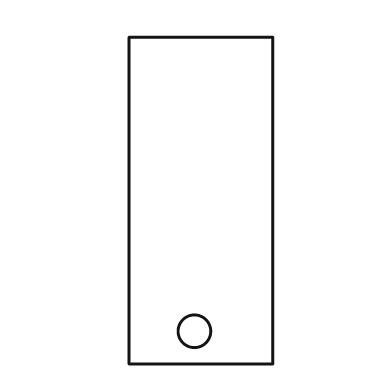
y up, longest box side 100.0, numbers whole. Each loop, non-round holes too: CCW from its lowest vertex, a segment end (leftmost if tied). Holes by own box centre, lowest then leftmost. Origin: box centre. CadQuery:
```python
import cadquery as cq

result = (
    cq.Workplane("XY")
    .moveTo(-22.0, -50.0)
    .lineTo(22.0, -50.0)
    .lineTo(22.0, 50.0)
    .lineTo(-22.0, 50.0)
    .close()
    .moveTo(-2.0, -40.0)
    .circle(5.0)
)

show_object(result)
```